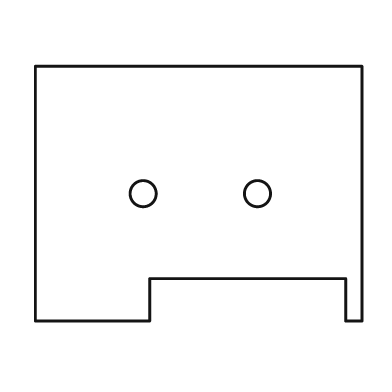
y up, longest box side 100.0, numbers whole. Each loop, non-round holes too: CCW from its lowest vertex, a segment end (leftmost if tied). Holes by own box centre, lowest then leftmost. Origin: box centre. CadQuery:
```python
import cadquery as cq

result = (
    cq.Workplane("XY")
    .moveTo(-50.0, -39.0)
    .lineTo(-15.0, -39.0)
    .lineTo(-15.0, -26.0)
    .lineTo(45.0, -26.0)
    .lineTo(45.0, -39.0)
    .lineTo(50.0, -39.0)
    .lineTo(50.0, 39.0)
    .lineTo(-50.0, 39.0)
    .close()
    .moveTo(-17.0, 0.0)
    .circle(4.0)
    .moveTo(18.0, 0.0)
    .circle(4.0)
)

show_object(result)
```